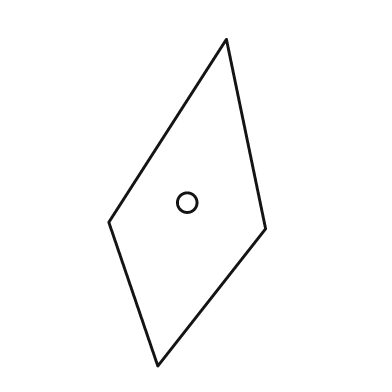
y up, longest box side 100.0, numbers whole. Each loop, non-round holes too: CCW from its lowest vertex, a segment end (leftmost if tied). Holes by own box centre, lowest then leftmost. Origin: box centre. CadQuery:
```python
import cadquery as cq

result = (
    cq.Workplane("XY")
    .moveTo(-9.0, -50.0)
    .lineTo(24.0, -8.0)
    .lineTo(12.0, 50.0)
    .lineTo(-24.0, -6.0)
    .close()
    .moveTo(0.0, 0.0)
    .circle(3.0)
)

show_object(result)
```